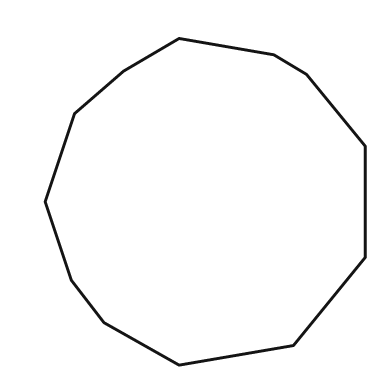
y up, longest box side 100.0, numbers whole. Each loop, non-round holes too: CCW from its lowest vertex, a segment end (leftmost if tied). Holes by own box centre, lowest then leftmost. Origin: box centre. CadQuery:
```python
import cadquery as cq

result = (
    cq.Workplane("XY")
    .moveTo(-8.0, -50.0)
    .lineTo(27.0, -44.0)
    .lineTo(49.0, -17.0)
    .lineTo(49.0, 17.0)
    .lineTo(31.0, 39.0)
    .lineTo(21.0, 45.0)
    .lineTo(-8.0, 50.0)
    .lineTo(-25.0, 40.0)
    .lineTo(-40.0, 27.0)
    .lineTo(-49.0, 0.0)
    .lineTo(-41.0, -24.0)
    .lineTo(-31.0, -37.0)
    .close()
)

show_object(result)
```